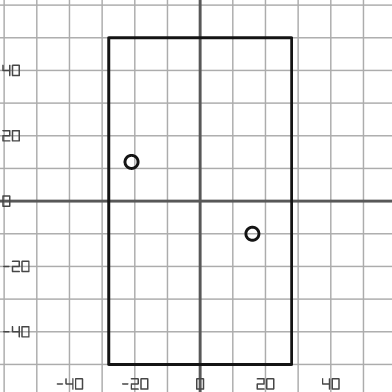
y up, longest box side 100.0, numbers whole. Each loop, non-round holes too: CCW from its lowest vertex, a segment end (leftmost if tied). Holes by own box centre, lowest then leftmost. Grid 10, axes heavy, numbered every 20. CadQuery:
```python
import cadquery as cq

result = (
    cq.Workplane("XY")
    .moveTo(-28.0, -50.0)
    .lineTo(28.0, -50.0)
    .lineTo(28.0, 50.0)
    .lineTo(-28.0, 50.0)
    .close()
    .moveTo(16.0, -10.0)
    .circle(2.0)
    .moveTo(-21.0, 12.0)
    .circle(2.0)
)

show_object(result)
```